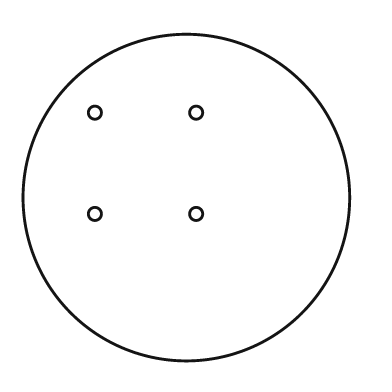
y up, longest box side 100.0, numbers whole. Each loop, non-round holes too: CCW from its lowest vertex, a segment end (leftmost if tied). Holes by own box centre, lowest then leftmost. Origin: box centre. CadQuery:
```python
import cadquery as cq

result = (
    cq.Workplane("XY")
    .moveTo(0.0, 0.0)
    .circle(50.0)
    .moveTo(-28.0, -5.0)
    .circle(2.0)
    .moveTo(3.0, -5.0)
    .circle(2.0)
    .moveTo(-28.0, 26.0)
    .circle(2.0)
    .moveTo(3.0, 26.0)
    .circle(2.0)
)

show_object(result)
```